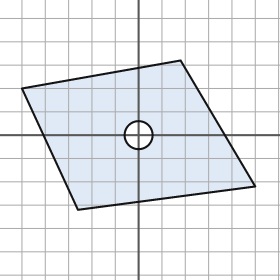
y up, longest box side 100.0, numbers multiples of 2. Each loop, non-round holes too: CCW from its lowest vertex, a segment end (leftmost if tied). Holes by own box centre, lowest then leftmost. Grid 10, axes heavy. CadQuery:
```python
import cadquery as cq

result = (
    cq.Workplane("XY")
    .moveTo(-26.0, -32.0)
    .lineTo(50.0, -22.0)
    .lineTo(18.0, 32.0)
    .lineTo(-50.0, 20.0)
    .close()
    .moveTo(0.0, 0.0)
    .circle(6.0)
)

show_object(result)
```